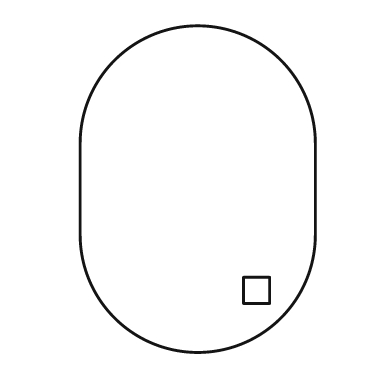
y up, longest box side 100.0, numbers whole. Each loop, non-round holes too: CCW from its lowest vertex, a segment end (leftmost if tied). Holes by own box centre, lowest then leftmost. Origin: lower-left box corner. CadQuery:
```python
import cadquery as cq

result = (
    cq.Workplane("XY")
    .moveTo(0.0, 36.0)
    .threePointArc((36.0, 0.0), (72.0, 36.0))
    .lineTo(72.0, 64.0)
    .threePointArc((36.0, 100.0), (0.0, 64.0))
    .close()
    .moveTo(50.0, 15.0)
    .lineTo(58.0, 15.0)
    .lineTo(58.0, 23.0)
    .lineTo(50.0, 23.0)
    .close()
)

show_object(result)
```